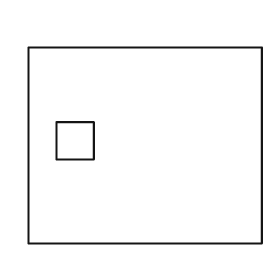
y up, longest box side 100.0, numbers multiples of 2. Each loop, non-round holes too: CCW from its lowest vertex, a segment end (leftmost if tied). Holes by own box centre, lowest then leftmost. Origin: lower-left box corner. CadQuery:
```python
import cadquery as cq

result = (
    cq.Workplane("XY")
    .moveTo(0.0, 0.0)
    .lineTo(100.0, 0.0)
    .lineTo(100.0, 84.0)
    .lineTo(0.0, 84.0)
    .close()
    .moveTo(12.0, 36.0)
    .lineTo(28.0, 36.0)
    .lineTo(28.0, 52.0)
    .lineTo(12.0, 52.0)
    .close()
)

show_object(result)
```